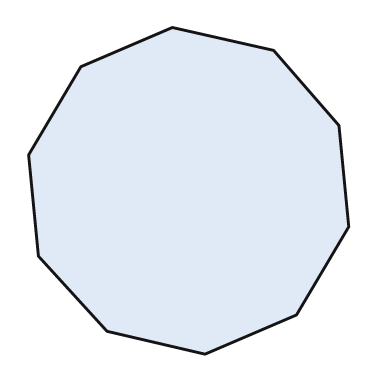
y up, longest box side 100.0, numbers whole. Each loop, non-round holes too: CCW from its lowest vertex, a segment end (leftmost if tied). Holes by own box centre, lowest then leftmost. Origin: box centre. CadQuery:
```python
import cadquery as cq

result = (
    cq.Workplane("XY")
    .moveTo(5.0, -50.0)
    .lineTo(33.0, -38.0)
    .lineTo(49.0, -11.0)
    .lineTo(46.0, 20.0)
    .lineTo(26.0, 43.0)
    .lineTo(-5.0, 50.0)
    .lineTo(-33.0, 38.0)
    .lineTo(-49.0, 11.0)
    .lineTo(-46.0, -20.0)
    .lineTo(-25.0, -43.0)
    .close()
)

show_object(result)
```